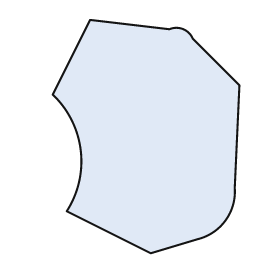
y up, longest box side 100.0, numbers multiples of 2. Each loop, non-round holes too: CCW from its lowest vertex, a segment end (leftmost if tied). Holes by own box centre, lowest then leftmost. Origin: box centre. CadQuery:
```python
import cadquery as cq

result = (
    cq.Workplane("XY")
    .moveTo(2.0, -50.0)
    .lineTo(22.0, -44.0)
    .threePointArc((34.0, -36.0), (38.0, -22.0))
    .lineTo(40.0, 22.0)
    .lineTo(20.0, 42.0)
    .threePointArc((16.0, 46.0), (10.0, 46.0))
    .lineTo(-24.0, 50.0)
    .lineTo(-40.0, 18.0)
    .threePointArc((-28.0, -6.0), (-34.0, -32.0))
    .close()
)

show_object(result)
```